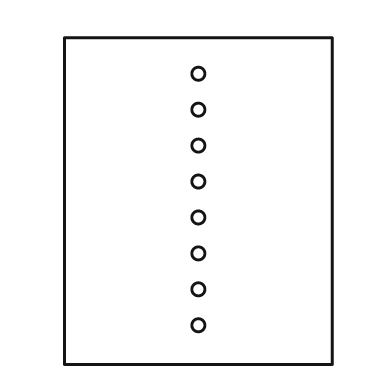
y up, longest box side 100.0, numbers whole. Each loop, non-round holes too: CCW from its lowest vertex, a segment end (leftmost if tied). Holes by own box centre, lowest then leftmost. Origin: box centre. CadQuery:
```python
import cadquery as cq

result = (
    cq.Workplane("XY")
    .moveTo(-41.0, -50.0)
    .lineTo(41.0, -50.0)
    .lineTo(41.0, 50.0)
    .lineTo(-41.0, 50.0)
    .close()
    .moveTo(0.0, -38.0)
    .circle(2.0)
    .moveTo(0.0, -27.0)
    .circle(2.0)
    .moveTo(0.0, -16.0)
    .circle(2.0)
    .moveTo(0.0, -5.0)
    .circle(2.0)
    .moveTo(0.0, 6.0)
    .circle(2.0)
    .moveTo(0.0, 17.0)
    .circle(2.0)
    .moveTo(0.0, 28.0)
    .circle(2.0)
    .moveTo(0.0, 39.0)
    .circle(2.0)
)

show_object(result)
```